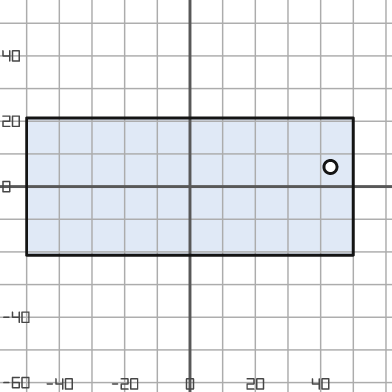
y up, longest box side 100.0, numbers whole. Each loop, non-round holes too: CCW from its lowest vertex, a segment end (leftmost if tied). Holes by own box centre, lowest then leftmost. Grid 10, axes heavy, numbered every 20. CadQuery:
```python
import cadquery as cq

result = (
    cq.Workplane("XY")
    .moveTo(-50.0, -21.0)
    .lineTo(50.0, -21.0)
    .lineTo(50.0, 21.0)
    .lineTo(-50.0, 21.0)
    .close()
    .moveTo(43.0, 6.0)
    .circle(2.0)
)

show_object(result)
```